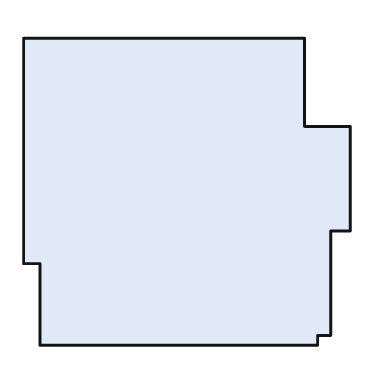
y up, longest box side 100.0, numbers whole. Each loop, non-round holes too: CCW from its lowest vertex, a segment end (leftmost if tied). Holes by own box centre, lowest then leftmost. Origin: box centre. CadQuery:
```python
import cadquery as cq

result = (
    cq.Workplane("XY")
    .moveTo(-45.0, -47.0)
    .lineTo(40.0, -47.0)
    .lineTo(40.0, -44.0)
    .lineTo(44.0, -44.0)
    .lineTo(44.0, -12.0)
    .lineTo(50.0, -12.0)
    .lineTo(50.0, 20.0)
    .lineTo(36.0, 20.0)
    .lineTo(36.0, 47.0)
    .lineTo(-50.0, 47.0)
    .lineTo(-50.0, -22.0)
    .lineTo(-45.0, -22.0)
    .close()
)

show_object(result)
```